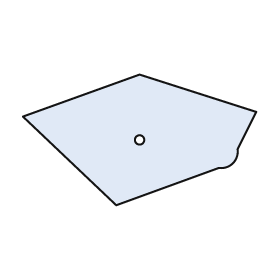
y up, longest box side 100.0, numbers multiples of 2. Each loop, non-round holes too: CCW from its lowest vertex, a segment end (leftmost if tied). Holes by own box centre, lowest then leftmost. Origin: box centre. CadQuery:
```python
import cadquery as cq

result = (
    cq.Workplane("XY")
    .moveTo(-10.0, -28.0)
    .lineTo(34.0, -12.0)
    .threePointArc((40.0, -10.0), (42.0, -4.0))
    .lineTo(50.0, 12.0)
    .lineTo(0.0, 28.0)
    .lineTo(-50.0, 10.0)
    .close()
    .moveTo(0.0, 0.0)
    .circle(2.0)
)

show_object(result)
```